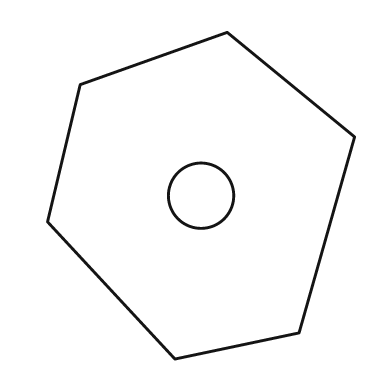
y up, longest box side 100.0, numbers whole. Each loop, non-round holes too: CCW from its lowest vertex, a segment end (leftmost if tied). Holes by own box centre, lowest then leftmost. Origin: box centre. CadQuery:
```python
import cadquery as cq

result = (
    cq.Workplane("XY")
    .moveTo(-8.0, -50.0)
    .lineTo(30.0, -42.0)
    .lineTo(47.0, 18.0)
    .lineTo(8.0, 50.0)
    .lineTo(-37.0, 34.0)
    .lineTo(-47.0, -8.0)
    .close()
    .moveTo(0.0, 0.0)
    .circle(10.0)
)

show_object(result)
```